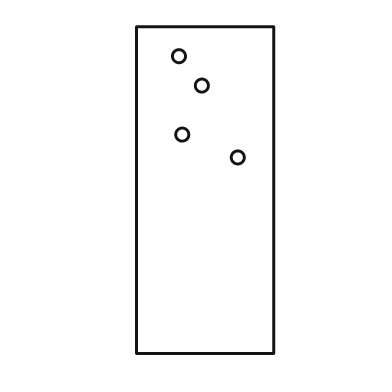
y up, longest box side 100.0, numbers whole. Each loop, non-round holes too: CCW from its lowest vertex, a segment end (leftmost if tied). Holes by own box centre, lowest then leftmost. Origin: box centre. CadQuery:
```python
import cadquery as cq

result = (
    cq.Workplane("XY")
    .moveTo(-21.0, -50.0)
    .lineTo(21.0, -50.0)
    .lineTo(21.0, 50.0)
    .lineTo(-21.0, 50.0)
    .close()
    .moveTo(10.0, 10.0)
    .circle(2.0)
    .moveTo(-7.0, 17.0)
    .circle(2.0)
    .moveTo(-1.0, 32.0)
    .circle(2.0)
    .moveTo(-8.0, 41.0)
    .circle(2.0)
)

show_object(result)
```